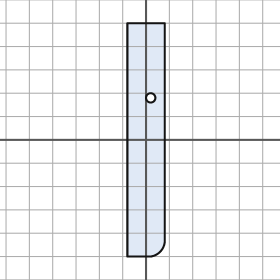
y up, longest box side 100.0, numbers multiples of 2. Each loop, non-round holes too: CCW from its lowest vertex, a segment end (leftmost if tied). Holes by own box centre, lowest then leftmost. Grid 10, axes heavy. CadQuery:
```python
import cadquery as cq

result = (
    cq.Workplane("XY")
    .moveTo(-8.0, -50.0)
    .lineTo(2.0, -50.0)
    .threePointArc((6.0, -48.0), (8.0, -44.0))
    .lineTo(8.0, 50.0)
    .lineTo(-8.0, 50.0)
    .close()
    .moveTo(2.0, 18.0)
    .circle(2.0)
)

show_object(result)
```